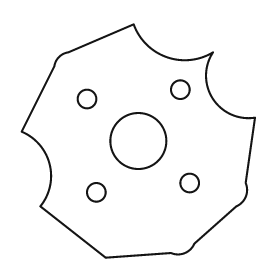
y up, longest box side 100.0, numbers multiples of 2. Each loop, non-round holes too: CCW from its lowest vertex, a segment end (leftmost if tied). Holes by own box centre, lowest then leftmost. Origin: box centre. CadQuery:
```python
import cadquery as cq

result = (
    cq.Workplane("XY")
    .moveTo(-14.0, -50.0)
    .lineTo(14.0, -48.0)
    .threePointArc((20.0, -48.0), (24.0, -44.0))
    .lineTo(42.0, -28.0)
    .threePointArc((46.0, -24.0), (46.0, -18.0))
    .lineTo(50.0, 10.0)
    .threePointArc((32.0, 18.0), (32.0, 38.0))
    .threePointArc((12.0, 36.0), (-2.0, 50.0))
    .lineTo(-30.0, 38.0)
    .threePointArc((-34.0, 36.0), (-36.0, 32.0))
    .lineTo(-50.0, 4.0)
    .threePointArc((-38.0, -10.0), (-42.0, -28.0))
    .close()
    .moveTo(-18.0, -22.0)
    .circle(4.0)
    .moveTo(22.0, -18.0)
    .circle(4.0)
    .moveTo(0.0, 0.0)
    .circle(12.0)
    .moveTo(-22.0, 18.0)
    .circle(4.0)
    .moveTo(18.0, 22.0)
    .circle(4.0)
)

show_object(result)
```